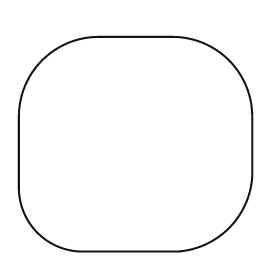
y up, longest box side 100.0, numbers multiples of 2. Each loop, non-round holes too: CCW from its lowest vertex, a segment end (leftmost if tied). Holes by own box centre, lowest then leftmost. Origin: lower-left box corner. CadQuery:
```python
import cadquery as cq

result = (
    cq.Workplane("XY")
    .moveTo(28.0, 0.0)
    .lineTo(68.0, 0.0)
    .threePointArc((90.0, 10.0), (100.0, 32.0))
    .lineTo(100.0, 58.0)
    .threePointArc((90.0, 82.0), (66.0, 92.0))
    .lineTo(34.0, 92.0)
    .threePointArc((10.0, 82.0), (0.0, 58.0))
    .lineTo(0.0, 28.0)
    .threePointArc((8.0, 8.0), (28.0, 0.0))
    .close()
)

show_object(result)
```